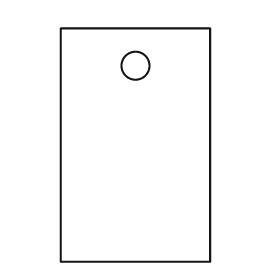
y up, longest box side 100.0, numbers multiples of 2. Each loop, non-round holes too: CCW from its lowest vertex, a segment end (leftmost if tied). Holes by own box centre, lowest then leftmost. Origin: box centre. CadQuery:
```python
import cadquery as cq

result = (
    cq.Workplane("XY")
    .moveTo(-32.0, -50.0)
    .lineTo(32.0, -50.0)
    .lineTo(32.0, 50.0)
    .lineTo(-32.0, 50.0)
    .close()
    .moveTo(0.0, 34.0)
    .circle(6.0)
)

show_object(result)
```